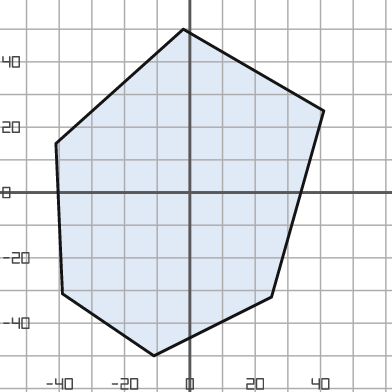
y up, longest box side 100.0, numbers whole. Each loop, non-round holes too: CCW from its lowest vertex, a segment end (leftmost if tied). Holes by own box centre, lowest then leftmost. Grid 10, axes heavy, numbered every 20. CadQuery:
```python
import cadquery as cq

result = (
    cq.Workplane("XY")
    .moveTo(-11.0, -50.0)
    .lineTo(25.0, -32.0)
    .lineTo(41.0, 25.0)
    .lineTo(-2.0, 50.0)
    .lineTo(-41.0, 15.0)
    .lineTo(-39.0, -31.0)
    .close()
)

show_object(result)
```